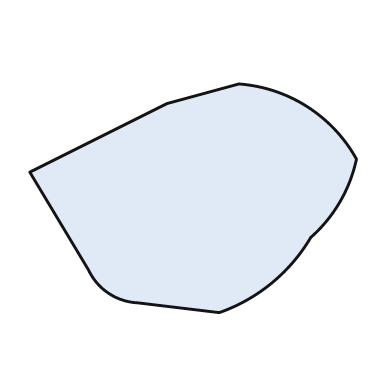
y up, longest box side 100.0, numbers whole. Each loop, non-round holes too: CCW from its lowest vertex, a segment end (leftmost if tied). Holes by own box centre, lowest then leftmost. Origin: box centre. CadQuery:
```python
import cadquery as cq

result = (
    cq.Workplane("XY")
    .moveTo(8.0, -35.0)
    .threePointArc((24.0, -26.0), (36.0, -12.0))
    .threePointArc((45.0, -1.0), (50.0, 12.0))
    .threePointArc((35.0, 28.0), (14.0, 35.0))
    .lineTo(-8.0, 29.0)
    .lineTo(-50.0, 8.0)
    .lineTo(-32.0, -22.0)
    .threePointArc((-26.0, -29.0), (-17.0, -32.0))
    .close()
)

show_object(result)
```